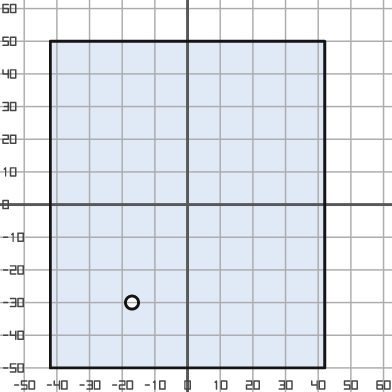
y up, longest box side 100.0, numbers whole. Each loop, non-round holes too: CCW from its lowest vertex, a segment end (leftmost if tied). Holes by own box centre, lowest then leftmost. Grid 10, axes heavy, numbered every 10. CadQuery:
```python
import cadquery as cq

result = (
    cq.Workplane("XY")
    .moveTo(-42.0, -50.0)
    .lineTo(42.0, -50.0)
    .lineTo(42.0, 50.0)
    .lineTo(-42.0, 50.0)
    .close()
    .moveTo(-17.0, -30.0)
    .circle(2.0)
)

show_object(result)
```